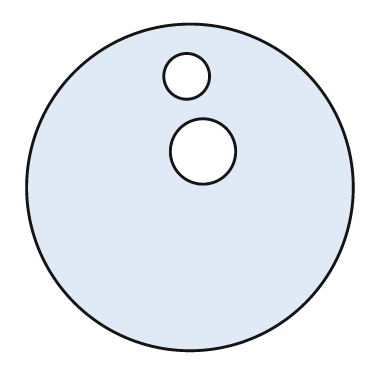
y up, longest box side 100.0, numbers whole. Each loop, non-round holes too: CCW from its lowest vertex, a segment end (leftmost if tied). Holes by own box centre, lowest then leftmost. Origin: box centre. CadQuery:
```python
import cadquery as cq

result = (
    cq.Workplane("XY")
    .moveTo(0.0, 0.0)
    .circle(50.0)
    .moveTo(4.0, 11.0)
    .circle(10.0)
    .moveTo(-1.0, 34.0)
    .circle(7.0)
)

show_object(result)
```